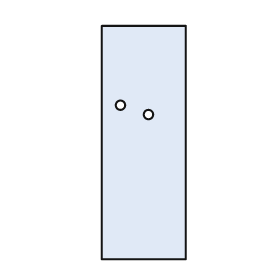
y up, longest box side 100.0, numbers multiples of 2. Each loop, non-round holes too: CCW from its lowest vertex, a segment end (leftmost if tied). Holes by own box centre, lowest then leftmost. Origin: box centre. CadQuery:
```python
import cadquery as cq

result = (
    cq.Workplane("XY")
    .moveTo(-18.0, -50.0)
    .lineTo(18.0, -50.0)
    .lineTo(18.0, 50.0)
    .lineTo(-18.0, 50.0)
    .close()
    .moveTo(2.0, 12.0)
    .circle(2.0)
    .moveTo(-10.0, 16.0)
    .circle(2.0)
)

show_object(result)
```